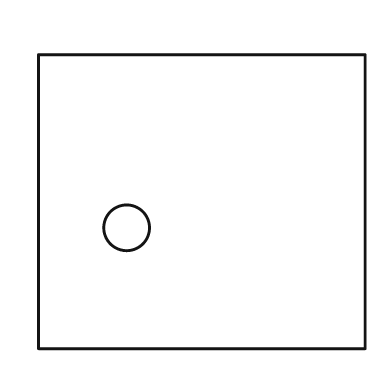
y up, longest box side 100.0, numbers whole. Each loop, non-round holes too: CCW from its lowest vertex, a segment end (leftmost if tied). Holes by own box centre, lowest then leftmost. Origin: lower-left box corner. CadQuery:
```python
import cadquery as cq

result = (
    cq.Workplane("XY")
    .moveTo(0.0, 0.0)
    .lineTo(100.0, 0.0)
    .lineTo(100.0, 90.0)
    .lineTo(0.0, 90.0)
    .close()
    .moveTo(27.0, 37.0)
    .circle(7.0)
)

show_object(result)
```